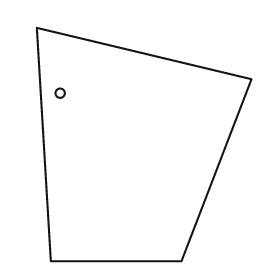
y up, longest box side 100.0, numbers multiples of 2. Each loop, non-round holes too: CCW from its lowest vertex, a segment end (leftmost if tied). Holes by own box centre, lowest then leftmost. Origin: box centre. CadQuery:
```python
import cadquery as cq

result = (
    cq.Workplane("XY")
    .moveTo(-40.0, -50.0)
    .lineTo(16.0, -50.0)
    .lineTo(46.0, 28.0)
    .lineTo(-46.0, 50.0)
    .close()
    .moveTo(-36.0, 22.0)
    .circle(2.0)
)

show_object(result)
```